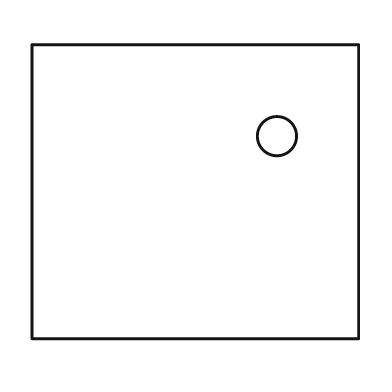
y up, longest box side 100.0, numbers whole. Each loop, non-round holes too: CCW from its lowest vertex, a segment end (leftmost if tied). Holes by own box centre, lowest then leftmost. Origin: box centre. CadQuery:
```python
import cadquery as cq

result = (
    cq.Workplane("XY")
    .moveTo(-50.0, -45.0)
    .lineTo(50.0, -45.0)
    .lineTo(50.0, 45.0)
    .lineTo(-50.0, 45.0)
    .close()
    .moveTo(25.0, 17.0)
    .circle(6.0)
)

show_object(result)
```